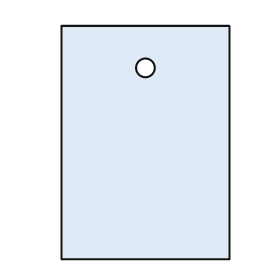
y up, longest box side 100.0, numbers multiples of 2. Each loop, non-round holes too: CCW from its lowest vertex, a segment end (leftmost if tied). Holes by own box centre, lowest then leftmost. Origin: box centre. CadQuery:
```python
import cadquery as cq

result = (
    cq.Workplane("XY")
    .moveTo(-36.0, -50.0)
    .lineTo(36.0, -50.0)
    .lineTo(36.0, 50.0)
    .lineTo(-36.0, 50.0)
    .close()
    .moveTo(0.0, 32.0)
    .circle(4.0)
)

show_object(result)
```